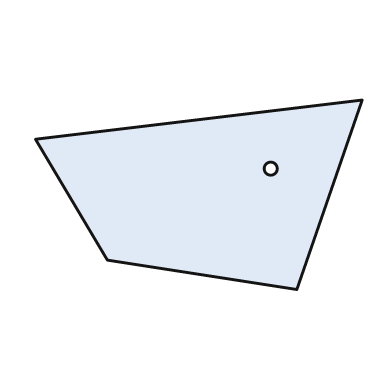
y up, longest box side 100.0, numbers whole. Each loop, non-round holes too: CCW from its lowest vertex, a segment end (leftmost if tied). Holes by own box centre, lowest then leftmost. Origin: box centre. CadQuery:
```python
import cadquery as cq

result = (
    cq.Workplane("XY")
    .moveTo(30.0, -29.0)
    .lineTo(50.0, 29.0)
    .lineTo(-50.0, 17.0)
    .lineTo(-28.0, -20.0)
    .close()
    .moveTo(22.0, 8.0)
    .circle(2.0)
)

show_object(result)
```